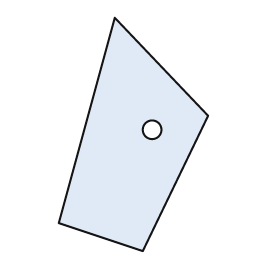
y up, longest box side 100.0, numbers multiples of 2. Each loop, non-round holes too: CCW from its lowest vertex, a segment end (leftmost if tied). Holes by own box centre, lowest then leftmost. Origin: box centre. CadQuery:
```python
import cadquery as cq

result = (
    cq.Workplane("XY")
    .moveTo(4.0, -50.0)
    .lineTo(32.0, 8.0)
    .lineTo(-8.0, 50.0)
    .lineTo(-32.0, -38.0)
    .close()
    .moveTo(8.0, 2.0)
    .circle(4.0)
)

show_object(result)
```